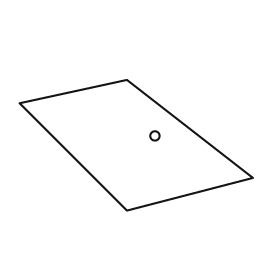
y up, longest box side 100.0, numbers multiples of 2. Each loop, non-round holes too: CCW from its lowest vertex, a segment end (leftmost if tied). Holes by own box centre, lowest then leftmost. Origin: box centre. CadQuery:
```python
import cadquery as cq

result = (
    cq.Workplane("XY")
    .moveTo(-4.0, -28.0)
    .lineTo(50.0, -14.0)
    .lineTo(-4.0, 28.0)
    .lineTo(-50.0, 18.0)
    .close()
    .moveTo(8.0, 4.0)
    .circle(2.0)
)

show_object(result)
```